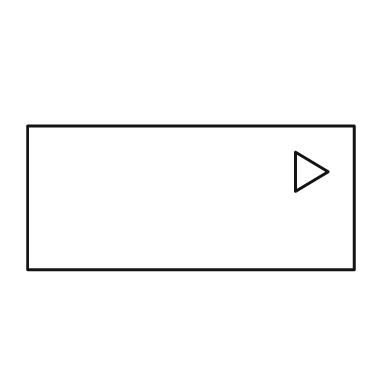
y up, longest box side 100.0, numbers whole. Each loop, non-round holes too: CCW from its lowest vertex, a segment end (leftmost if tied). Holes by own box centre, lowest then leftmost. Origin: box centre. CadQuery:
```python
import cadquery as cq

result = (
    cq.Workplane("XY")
    .moveTo(-50.0, -22.0)
    .lineTo(50.0, -22.0)
    .lineTo(50.0, 22.0)
    .lineTo(-50.0, 22.0)
    .close()
    .moveTo(32.0, 2.0)
    .lineTo(42.0, 8.0)
    .lineTo(32.0, 14.0)
    .close()
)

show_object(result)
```